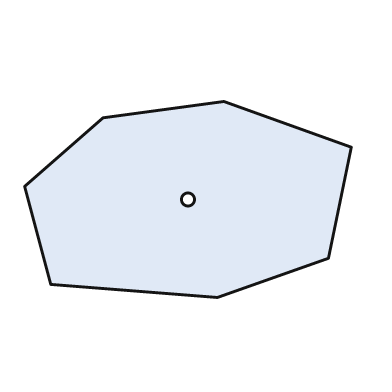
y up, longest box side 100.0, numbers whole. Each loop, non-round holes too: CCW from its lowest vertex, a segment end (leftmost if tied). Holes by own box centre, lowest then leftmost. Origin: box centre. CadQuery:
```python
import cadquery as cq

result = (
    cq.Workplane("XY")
    .moveTo(9.0, -30.0)
    .lineTo(43.0, -18.0)
    .lineTo(50.0, 16.0)
    .lineTo(11.0, 30.0)
    .lineTo(-26.0, 25.0)
    .lineTo(-50.0, 4.0)
    .lineTo(-42.0, -26.0)
    .close()
    .moveTo(0.0, 0.0)
    .circle(2.0)
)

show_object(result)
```